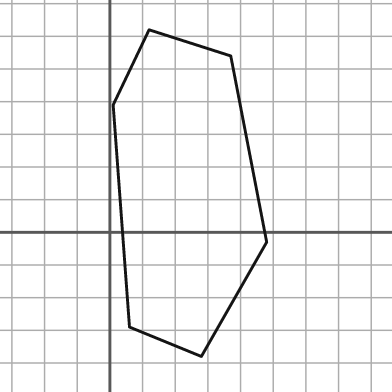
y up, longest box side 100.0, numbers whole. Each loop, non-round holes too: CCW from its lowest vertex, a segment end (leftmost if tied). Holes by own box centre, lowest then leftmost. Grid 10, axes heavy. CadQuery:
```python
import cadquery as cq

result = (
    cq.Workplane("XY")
    .moveTo(28.0, -38.0)
    .lineTo(48.0, -3.0)
    .lineTo(37.0, 54.0)
    .lineTo(12.0, 62.0)
    .lineTo(1.0, 39.0)
    .lineTo(6.0, -29.0)
    .close()
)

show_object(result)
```